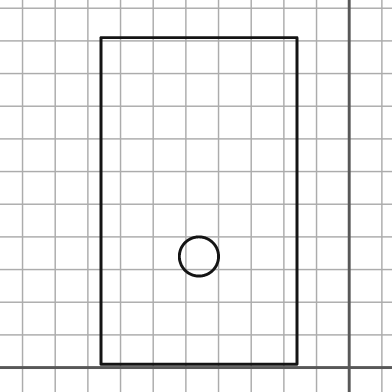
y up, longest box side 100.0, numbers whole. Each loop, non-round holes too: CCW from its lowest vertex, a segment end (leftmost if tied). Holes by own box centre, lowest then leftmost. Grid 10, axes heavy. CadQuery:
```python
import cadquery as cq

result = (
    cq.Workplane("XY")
    .moveTo(-76.0, 1.0)
    .lineTo(-16.0, 1.0)
    .lineTo(-16.0, 101.0)
    .lineTo(-76.0, 101.0)
    .close()
    .moveTo(-46.0, 34.0)
    .circle(6.0)
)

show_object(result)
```